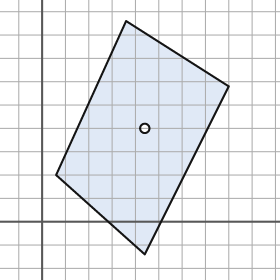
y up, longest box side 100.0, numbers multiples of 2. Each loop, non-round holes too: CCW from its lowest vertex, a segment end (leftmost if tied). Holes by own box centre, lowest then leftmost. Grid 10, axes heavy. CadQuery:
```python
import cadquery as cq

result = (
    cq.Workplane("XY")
    .moveTo(44.0, -14.0)
    .lineTo(80.0, 58.0)
    .lineTo(36.0, 86.0)
    .lineTo(6.0, 20.0)
    .close()
    .moveTo(44.0, 40.0)
    .circle(2.0)
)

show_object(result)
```